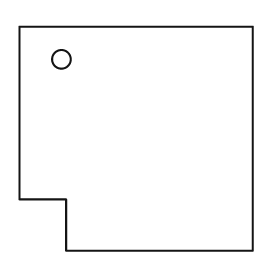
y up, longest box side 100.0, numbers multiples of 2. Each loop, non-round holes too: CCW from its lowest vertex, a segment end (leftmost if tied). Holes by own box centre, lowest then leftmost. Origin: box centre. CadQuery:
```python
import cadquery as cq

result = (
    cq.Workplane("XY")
    .moveTo(-30.0, -48.0)
    .lineTo(50.0, -48.0)
    .lineTo(50.0, 48.0)
    .lineTo(-50.0, 48.0)
    .lineTo(-50.0, -26.0)
    .lineTo(-30.0, -26.0)
    .close()
    .moveTo(-32.0, 34.0)
    .circle(4.0)
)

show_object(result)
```